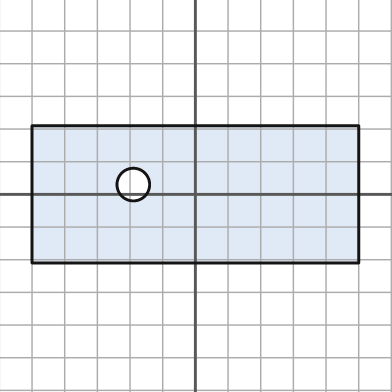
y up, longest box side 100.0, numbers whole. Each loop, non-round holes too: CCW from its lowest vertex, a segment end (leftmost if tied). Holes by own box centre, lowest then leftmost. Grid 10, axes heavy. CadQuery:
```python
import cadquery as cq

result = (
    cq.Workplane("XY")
    .moveTo(-50.0, -21.0)
    .lineTo(50.0, -21.0)
    .lineTo(50.0, 21.0)
    .lineTo(-50.0, 21.0)
    .close()
    .moveTo(-19.0, 3.0)
    .circle(5.0)
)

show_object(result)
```